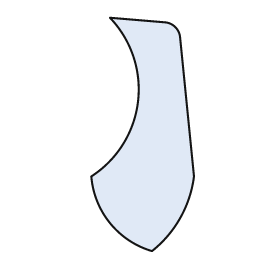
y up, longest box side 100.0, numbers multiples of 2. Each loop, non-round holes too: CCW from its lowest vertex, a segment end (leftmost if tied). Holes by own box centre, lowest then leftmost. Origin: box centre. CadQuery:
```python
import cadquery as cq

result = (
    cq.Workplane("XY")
    .moveTo(4.0, -50.0)
    .threePointArc((16.0, -36.0), (22.0, -18.0))
    .lineTo(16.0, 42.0)
    .threePointArc((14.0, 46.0), (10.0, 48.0))
    .lineTo(-14.0, 50.0)
    .threePointArc((-2.0, 14.0), (-22.0, -18.0))
    .threePointArc((-14.0, -38.0), (4.0, -50.0))
    .close()
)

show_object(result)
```